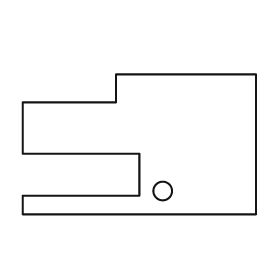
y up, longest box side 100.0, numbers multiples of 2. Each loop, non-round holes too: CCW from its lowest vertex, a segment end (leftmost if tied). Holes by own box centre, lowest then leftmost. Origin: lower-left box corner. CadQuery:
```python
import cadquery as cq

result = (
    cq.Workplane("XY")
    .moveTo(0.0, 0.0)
    .lineTo(100.0, 0.0)
    .lineTo(100.0, 60.0)
    .lineTo(40.0, 60.0)
    .lineTo(40.0, 48.0)
    .lineTo(0.0, 48.0)
    .lineTo(0.0, 26.0)
    .lineTo(50.0, 26.0)
    .lineTo(50.0, 8.0)
    .lineTo(0.0, 8.0)
    .close()
    .moveTo(60.0, 10.0)
    .circle(4.0)
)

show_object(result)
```